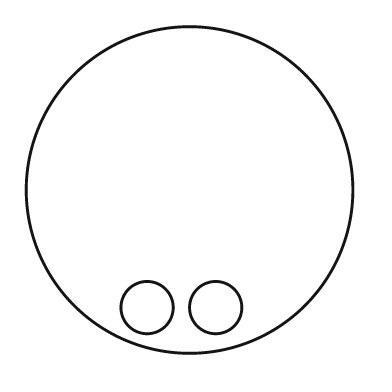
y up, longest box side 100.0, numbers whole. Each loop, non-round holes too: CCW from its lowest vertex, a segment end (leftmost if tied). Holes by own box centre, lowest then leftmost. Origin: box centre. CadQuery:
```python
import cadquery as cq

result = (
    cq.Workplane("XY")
    .moveTo(0.0, 0.0)
    .circle(50.0)
    .moveTo(-13.0, -36.0)
    .circle(8.0)
    .moveTo(8.0, -36.0)
    .circle(8.0)
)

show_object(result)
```